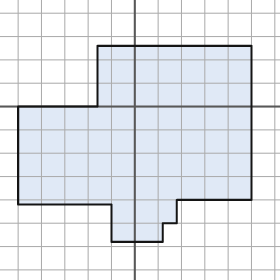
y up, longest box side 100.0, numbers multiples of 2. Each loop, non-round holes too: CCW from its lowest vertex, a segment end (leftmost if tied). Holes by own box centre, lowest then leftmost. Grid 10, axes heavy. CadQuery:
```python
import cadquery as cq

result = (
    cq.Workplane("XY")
    .moveTo(-10.0, -58.0)
    .lineTo(12.0, -58.0)
    .lineTo(12.0, -50.0)
    .lineTo(18.0, -50.0)
    .lineTo(18.0, -40.0)
    .lineTo(50.0, -40.0)
    .lineTo(50.0, 26.0)
    .lineTo(-16.0, 26.0)
    .lineTo(-16.0, 0.0)
    .lineTo(-50.0, 0.0)
    .lineTo(-50.0, -42.0)
    .lineTo(-10.0, -42.0)
    .close()
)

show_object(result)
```